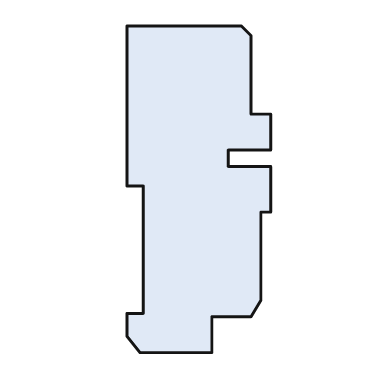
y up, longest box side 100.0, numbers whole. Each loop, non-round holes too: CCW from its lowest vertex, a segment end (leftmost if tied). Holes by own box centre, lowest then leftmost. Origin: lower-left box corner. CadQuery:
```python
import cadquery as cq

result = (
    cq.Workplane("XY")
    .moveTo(4.0, 0.0)
    .lineTo(26.0, 0.0)
    .lineTo(26.0, 11.0)
    .lineTo(38.0, 11.0)
    .lineTo(41.0, 16.0)
    .lineTo(41.0, 43.0)
    .lineTo(44.0, 43.0)
    .lineTo(44.0, 57.0)
    .lineTo(31.0, 57.0)
    .lineTo(31.0, 62.0)
    .lineTo(44.0, 62.0)
    .lineTo(44.0, 73.0)
    .lineTo(38.0, 73.0)
    .lineTo(38.0, 97.0)
    .lineTo(35.0, 100.0)
    .lineTo(0.0, 100.0)
    .lineTo(0.0, 51.0)
    .lineTo(5.0, 51.0)
    .lineTo(5.0, 12.0)
    .lineTo(0.0, 12.0)
    .lineTo(0.0, 5.0)
    .close()
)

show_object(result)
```